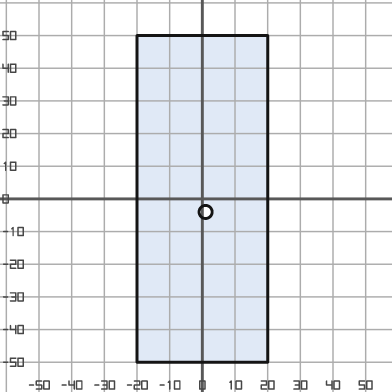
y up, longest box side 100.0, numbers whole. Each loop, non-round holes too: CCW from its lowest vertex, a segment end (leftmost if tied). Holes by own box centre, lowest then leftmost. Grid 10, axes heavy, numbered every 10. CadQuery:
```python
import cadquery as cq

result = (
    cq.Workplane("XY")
    .moveTo(-20.0, -50.0)
    .lineTo(20.0, -50.0)
    .lineTo(20.0, 50.0)
    .lineTo(-20.0, 50.0)
    .close()
    .moveTo(1.0, -4.0)
    .circle(2.0)
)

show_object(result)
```